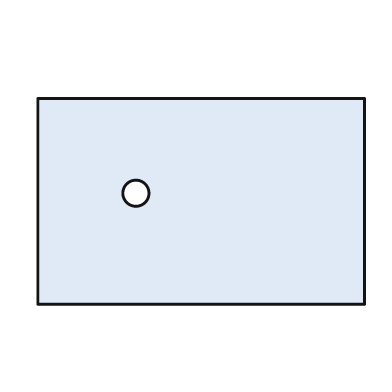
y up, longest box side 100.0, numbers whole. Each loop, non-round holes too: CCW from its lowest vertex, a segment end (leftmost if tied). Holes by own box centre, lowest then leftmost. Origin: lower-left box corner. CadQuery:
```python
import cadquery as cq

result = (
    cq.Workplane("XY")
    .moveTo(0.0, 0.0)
    .lineTo(100.0, 0.0)
    .lineTo(100.0, 63.0)
    .lineTo(0.0, 63.0)
    .close()
    .moveTo(30.0, 34.0)
    .circle(4.0)
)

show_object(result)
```